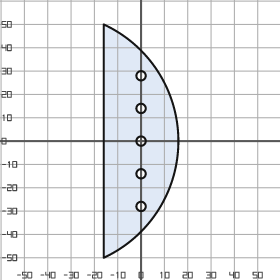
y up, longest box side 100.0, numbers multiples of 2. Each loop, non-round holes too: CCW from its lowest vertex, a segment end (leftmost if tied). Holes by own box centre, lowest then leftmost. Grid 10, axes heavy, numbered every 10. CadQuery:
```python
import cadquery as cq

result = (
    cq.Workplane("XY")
    .moveTo(-16.0, -50.0)
    .threePointArc((16.0, 0.0), (-16.0, 50.0))
    .close()
    .moveTo(0.0, -28.0)
    .circle(2.0)
    .moveTo(0.0, -14.0)
    .circle(2.0)
    .moveTo(0.0, 0.0)
    .circle(2.0)
    .moveTo(0.0, 14.0)
    .circle(2.0)
    .moveTo(0.0, 28.0)
    .circle(2.0)
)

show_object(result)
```